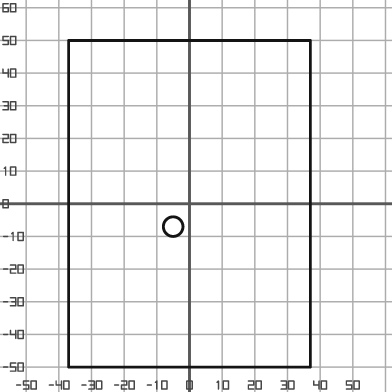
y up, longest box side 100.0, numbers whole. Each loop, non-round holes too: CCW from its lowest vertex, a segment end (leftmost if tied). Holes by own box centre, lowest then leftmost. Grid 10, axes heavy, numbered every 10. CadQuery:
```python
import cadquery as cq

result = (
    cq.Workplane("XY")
    .moveTo(-37.0, -50.0)
    .lineTo(37.0, -50.0)
    .lineTo(37.0, 50.0)
    .lineTo(-37.0, 50.0)
    .close()
    .moveTo(-5.0, -7.0)
    .circle(3.0)
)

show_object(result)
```